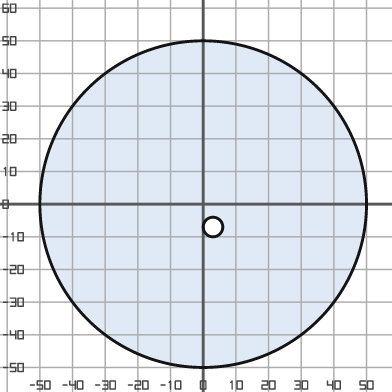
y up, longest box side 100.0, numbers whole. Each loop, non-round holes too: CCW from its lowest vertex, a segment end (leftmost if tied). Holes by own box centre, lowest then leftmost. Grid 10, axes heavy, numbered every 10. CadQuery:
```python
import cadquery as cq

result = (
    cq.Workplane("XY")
    .moveTo(0.0, 0.0)
    .circle(50.0)
    .moveTo(3.0, -7.0)
    .circle(3.0)
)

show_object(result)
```